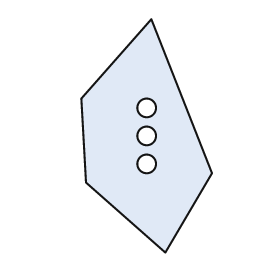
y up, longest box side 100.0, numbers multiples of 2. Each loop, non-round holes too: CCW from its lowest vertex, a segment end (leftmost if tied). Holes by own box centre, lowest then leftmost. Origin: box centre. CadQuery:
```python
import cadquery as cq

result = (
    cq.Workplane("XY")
    .moveTo(8.0, -50.0)
    .lineTo(28.0, -16.0)
    .lineTo(2.0, 50.0)
    .lineTo(-28.0, 16.0)
    .lineTo(-26.0, -20.0)
    .close()
    .moveTo(0.0, -12.0)
    .circle(4.0)
    .moveTo(0.0, 0.0)
    .circle(4.0)
    .moveTo(0.0, 12.0)
    .circle(4.0)
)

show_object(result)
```